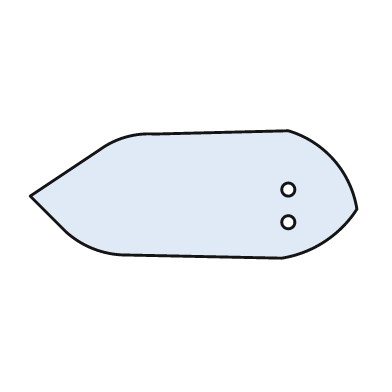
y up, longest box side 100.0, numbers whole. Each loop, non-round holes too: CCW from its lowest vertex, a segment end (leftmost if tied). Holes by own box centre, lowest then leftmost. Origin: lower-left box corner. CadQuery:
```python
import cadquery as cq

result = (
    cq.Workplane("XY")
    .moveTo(77.0, 0.0)
    .threePointArc((90.0, 5.0), (100.0, 15.0))
    .threePointArc((93.0, 30.0), (79.0, 39.0))
    .lineTo(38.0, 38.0)
    .threePointArc((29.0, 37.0), (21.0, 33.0))
    .lineTo(0.0, 19.0)
    .lineTo(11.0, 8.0)
    .threePointArc((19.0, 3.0), (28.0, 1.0))
    .close()
    .moveTo(79.0, 11.0)
    .circle(2.0)
    .moveTo(79.0, 21.0)
    .circle(2.0)
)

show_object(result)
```